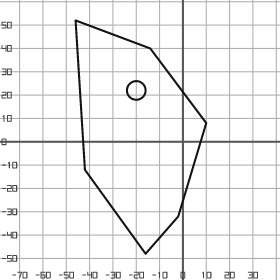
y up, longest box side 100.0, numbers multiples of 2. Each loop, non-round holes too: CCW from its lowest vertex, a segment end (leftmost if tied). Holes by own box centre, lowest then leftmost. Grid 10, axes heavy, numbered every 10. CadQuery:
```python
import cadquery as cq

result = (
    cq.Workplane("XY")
    .moveTo(-16.0, -48.0)
    .lineTo(-2.0, -32.0)
    .lineTo(10.0, 8.0)
    .lineTo(-14.0, 40.0)
    .lineTo(-46.0, 52.0)
    .lineTo(-42.0, -12.0)
    .close()
    .moveTo(-20.0, 22.0)
    .circle(4.0)
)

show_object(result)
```